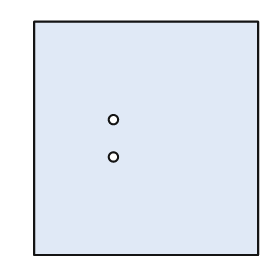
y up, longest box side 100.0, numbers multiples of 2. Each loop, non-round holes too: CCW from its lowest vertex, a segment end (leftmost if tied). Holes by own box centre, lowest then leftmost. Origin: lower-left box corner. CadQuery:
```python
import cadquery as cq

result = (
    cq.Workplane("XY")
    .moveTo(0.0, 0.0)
    .lineTo(96.0, 0.0)
    .lineTo(96.0, 100.0)
    .lineTo(0.0, 100.0)
    .close()
    .moveTo(34.0, 42.0)
    .circle(2.0)
    .moveTo(34.0, 58.0)
    .circle(2.0)
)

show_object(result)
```